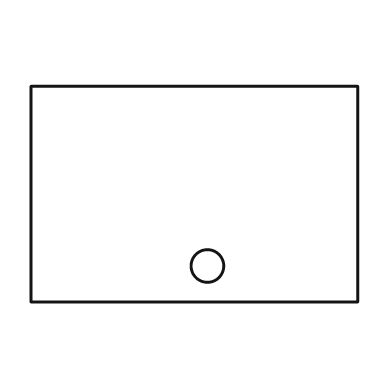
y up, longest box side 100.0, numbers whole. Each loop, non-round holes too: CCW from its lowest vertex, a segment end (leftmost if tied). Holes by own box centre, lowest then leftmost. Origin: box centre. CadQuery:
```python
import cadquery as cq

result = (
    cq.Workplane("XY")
    .moveTo(-50.0, -33.0)
    .lineTo(50.0, -33.0)
    .lineTo(50.0, 33.0)
    .lineTo(-50.0, 33.0)
    .close()
    .moveTo(4.0, -22.0)
    .circle(5.0)
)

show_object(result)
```